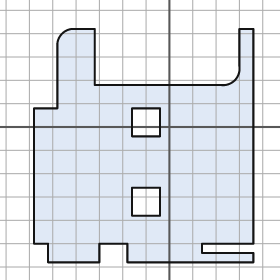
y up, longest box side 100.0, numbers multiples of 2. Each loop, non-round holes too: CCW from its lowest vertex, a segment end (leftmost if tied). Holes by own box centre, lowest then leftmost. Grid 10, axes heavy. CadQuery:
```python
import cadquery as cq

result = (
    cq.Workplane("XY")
    .moveTo(-52.0, -58.0)
    .lineTo(-30.0, -58.0)
    .lineTo(-30.0, -50.0)
    .lineTo(-18.0, -50.0)
    .lineTo(-18.0, -58.0)
    .lineTo(36.0, -58.0)
    .lineTo(36.0, -54.0)
    .lineTo(14.0, -54.0)
    .lineTo(14.0, -50.0)
    .lineTo(36.0, -50.0)
    .lineTo(36.0, 42.0)
    .lineTo(30.0, 42.0)
    .lineTo(30.0, 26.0)
    .threePointArc((28.0, 20.0), (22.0, 18.0))
    .lineTo(-32.0, 18.0)
    .lineTo(-32.0, 42.0)
    .lineTo(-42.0, 42.0)
    .threePointArc((-46.0, 40.0), (-48.0, 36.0))
    .lineTo(-48.0, 8.0)
    .lineTo(-58.0, 8.0)
    .lineTo(-58.0, -50.0)
    .lineTo(-52.0, -50.0)
    .close()
    .moveTo(-16.0, -38.0)
    .lineTo(-4.0, -38.0)
    .lineTo(-4.0, -26.0)
    .lineTo(-16.0, -26.0)
    .close()
    .moveTo(-16.0, -4.0)
    .lineTo(-4.0, -4.0)
    .lineTo(-4.0, 8.0)
    .lineTo(-16.0, 8.0)
    .close()
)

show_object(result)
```